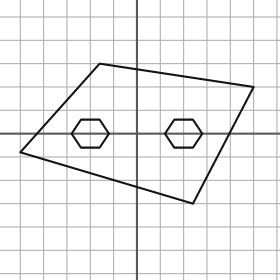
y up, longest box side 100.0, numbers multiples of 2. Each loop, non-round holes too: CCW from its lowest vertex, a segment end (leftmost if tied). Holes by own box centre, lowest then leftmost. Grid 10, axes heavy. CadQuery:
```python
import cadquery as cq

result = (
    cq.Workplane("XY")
    .moveTo(24.0, -30.0)
    .lineTo(50.0, 20.0)
    .lineTo(-16.0, 30.0)
    .lineTo(-50.0, -8.0)
    .close()
    .moveTo(-24.0, -6.0)
    .lineTo(-16.0, -6.0)
    .lineTo(-12.0, 0.0)
    .lineTo(-16.0, 6.0)
    .lineTo(-24.0, 6.0)
    .lineTo(-28.0, 0.0)
    .close()
    .moveTo(16.0, -6.0)
    .lineTo(24.0, -6.0)
    .lineTo(28.0, 0.0)
    .lineTo(24.0, 6.0)
    .lineTo(16.0, 6.0)
    .lineTo(12.0, 0.0)
    .close()
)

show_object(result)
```